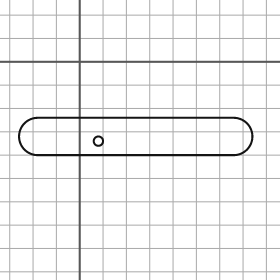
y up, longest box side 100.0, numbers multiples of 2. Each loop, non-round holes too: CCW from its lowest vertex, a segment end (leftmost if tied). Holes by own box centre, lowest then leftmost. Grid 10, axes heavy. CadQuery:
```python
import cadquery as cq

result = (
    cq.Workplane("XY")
    .moveTo(-18.0, -40.0)
    .lineTo(66.0, -40.0)
    .threePointArc((74.0, -32.0), (66.0, -24.0))
    .lineTo(-18.0, -24.0)
    .threePointArc((-26.0, -32.0), (-18.0, -40.0))
    .close()
    .moveTo(8.0, -34.0)
    .circle(2.0)
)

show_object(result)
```